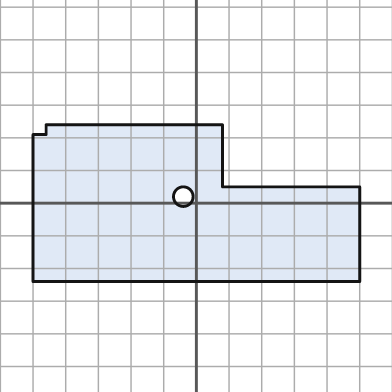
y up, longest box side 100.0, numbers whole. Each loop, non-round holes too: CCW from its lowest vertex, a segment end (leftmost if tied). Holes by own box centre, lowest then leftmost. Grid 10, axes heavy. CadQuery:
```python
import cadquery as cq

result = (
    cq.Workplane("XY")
    .moveTo(-50.0, -24.0)
    .lineTo(50.0, -24.0)
    .lineTo(50.0, 5.0)
    .lineTo(8.0, 5.0)
    .lineTo(8.0, 24.0)
    .lineTo(-46.0, 24.0)
    .lineTo(-46.0, 21.0)
    .lineTo(-50.0, 21.0)
    .close()
    .moveTo(-4.0, 2.0)
    .circle(3.0)
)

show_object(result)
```